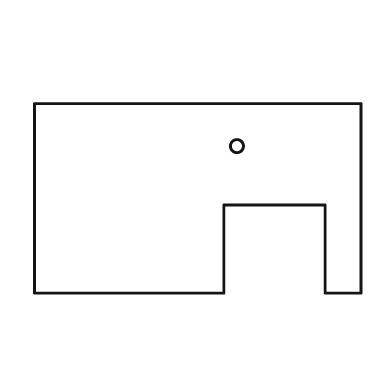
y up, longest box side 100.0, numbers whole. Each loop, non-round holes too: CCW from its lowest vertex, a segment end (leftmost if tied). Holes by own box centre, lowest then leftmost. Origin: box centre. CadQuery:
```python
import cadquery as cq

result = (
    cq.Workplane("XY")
    .moveTo(-50.0, -29.0)
    .lineTo(8.0, -29.0)
    .lineTo(8.0, -2.0)
    .lineTo(39.0, -2.0)
    .lineTo(39.0, -29.0)
    .lineTo(50.0, -29.0)
    .lineTo(50.0, 29.0)
    .lineTo(-50.0, 29.0)
    .close()
    .moveTo(12.0, 16.0)
    .circle(2.0)
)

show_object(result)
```